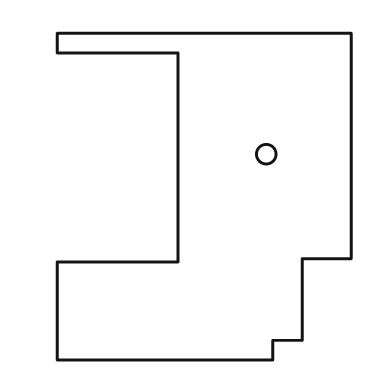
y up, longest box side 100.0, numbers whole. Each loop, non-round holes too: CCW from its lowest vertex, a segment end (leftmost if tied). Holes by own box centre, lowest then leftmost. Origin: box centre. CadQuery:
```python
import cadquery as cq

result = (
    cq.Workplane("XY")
    .moveTo(-45.0, -50.0)
    .lineTo(21.0, -50.0)
    .lineTo(21.0, -44.0)
    .lineTo(30.0, -44.0)
    .lineTo(30.0, -19.0)
    .lineTo(45.0, -19.0)
    .lineTo(45.0, 50.0)
    .lineTo(-45.0, 50.0)
    .lineTo(-45.0, 44.0)
    .lineTo(-8.0, 44.0)
    .lineTo(-8.0, -20.0)
    .lineTo(-45.0, -20.0)
    .close()
    .moveTo(19.0, 13.0)
    .circle(3.0)
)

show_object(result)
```